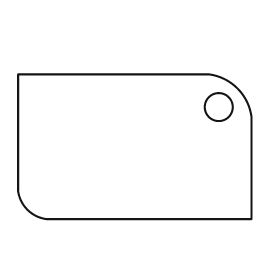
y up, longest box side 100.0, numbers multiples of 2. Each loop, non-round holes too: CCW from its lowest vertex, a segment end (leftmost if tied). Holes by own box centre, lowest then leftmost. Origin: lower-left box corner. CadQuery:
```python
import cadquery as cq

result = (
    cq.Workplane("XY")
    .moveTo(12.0, 0.0)
    .lineTo(100.0, 0.0)
    .lineTo(100.0, 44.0)
    .threePointArc((94.0, 56.0), (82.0, 62.0))
    .lineTo(0.0, 62.0)
    .lineTo(0.0, 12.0)
    .threePointArc((4.0, 4.0), (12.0, 0.0))
    .close()
    .moveTo(86.0, 48.0)
    .circle(6.0)
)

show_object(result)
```